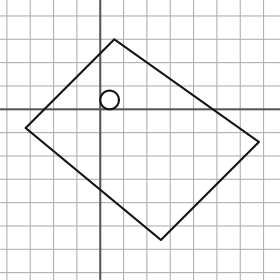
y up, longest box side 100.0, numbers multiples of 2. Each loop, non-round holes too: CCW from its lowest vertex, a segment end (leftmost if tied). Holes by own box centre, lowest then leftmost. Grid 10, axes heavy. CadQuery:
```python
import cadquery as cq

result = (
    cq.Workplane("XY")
    .moveTo(26.0, -56.0)
    .lineTo(68.0, -14.0)
    .lineTo(6.0, 30.0)
    .lineTo(-32.0, -8.0)
    .close()
    .moveTo(4.0, 4.0)
    .circle(4.0)
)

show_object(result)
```